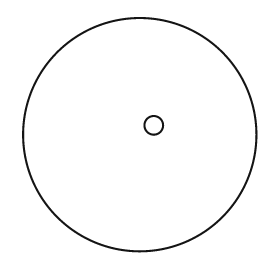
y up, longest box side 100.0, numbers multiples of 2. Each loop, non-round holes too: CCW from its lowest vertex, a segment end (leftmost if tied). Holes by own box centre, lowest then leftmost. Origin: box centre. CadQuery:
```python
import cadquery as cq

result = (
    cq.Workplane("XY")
    .moveTo(0.0, 0.0)
    .circle(50.0)
    .moveTo(6.0, 4.0)
    .circle(4.0)
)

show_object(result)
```